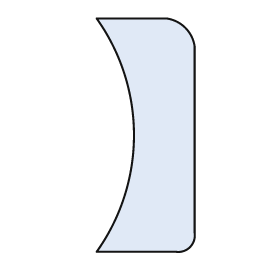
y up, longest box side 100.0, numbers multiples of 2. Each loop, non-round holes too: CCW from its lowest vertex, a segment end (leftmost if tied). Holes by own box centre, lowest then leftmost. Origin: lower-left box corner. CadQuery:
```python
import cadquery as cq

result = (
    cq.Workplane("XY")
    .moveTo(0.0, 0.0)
    .lineTo(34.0, 0.0)
    .threePointArc((40.0, 2.0), (42.0, 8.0))
    .lineTo(42.0, 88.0)
    .threePointArc((38.0, 96.0), (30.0, 100.0))
    .lineTo(0.0, 100.0)
    .threePointArc((16.0, 50.0), (0.0, 0.0))
    .close()
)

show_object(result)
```